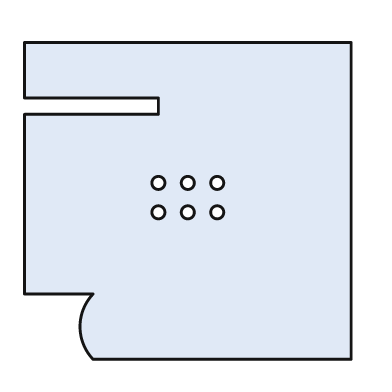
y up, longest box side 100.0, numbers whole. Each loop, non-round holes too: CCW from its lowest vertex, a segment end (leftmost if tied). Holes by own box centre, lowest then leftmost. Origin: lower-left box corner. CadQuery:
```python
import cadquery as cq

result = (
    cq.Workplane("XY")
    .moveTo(21.0, 0.0)
    .lineTo(100.0, 0.0)
    .lineTo(100.0, 97.0)
    .lineTo(0.0, 97.0)
    .lineTo(0.0, 80.0)
    .lineTo(41.0, 80.0)
    .lineTo(41.0, 75.0)
    .lineTo(0.0, 75.0)
    .lineTo(0.0, 20.0)
    .lineTo(21.0, 20.0)
    .threePointArc((17.0, 10.0), (21.0, 0.0))
    .close()
    .moveTo(41.0, 45.0)
    .circle(2.0)
    .moveTo(50.0, 45.0)
    .circle(2.0)
    .moveTo(59.0, 45.0)
    .circle(2.0)
    .moveTo(41.0, 54.0)
    .circle(2.0)
    .moveTo(50.0, 54.0)
    .circle(2.0)
    .moveTo(59.0, 54.0)
    .circle(2.0)
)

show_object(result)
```